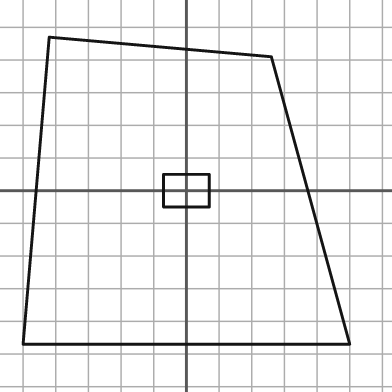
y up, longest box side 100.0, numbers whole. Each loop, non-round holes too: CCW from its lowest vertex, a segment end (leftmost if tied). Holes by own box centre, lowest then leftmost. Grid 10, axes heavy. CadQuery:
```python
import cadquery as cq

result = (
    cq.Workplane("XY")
    .moveTo(-50.0, -47.0)
    .lineTo(50.0, -47.0)
    .lineTo(26.0, 41.0)
    .lineTo(-42.0, 47.0)
    .close()
    .moveTo(-7.0, -5.0)
    .lineTo(7.0, -5.0)
    .lineTo(7.0, 5.0)
    .lineTo(-7.0, 5.0)
    .close()
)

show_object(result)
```